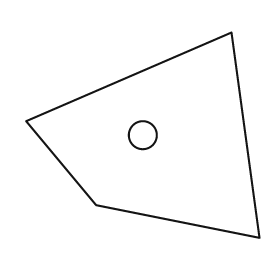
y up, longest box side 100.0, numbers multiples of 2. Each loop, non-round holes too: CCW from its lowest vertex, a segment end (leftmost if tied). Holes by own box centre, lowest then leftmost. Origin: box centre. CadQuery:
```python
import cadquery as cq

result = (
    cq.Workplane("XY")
    .moveTo(50.0, -44.0)
    .lineTo(38.0, 44.0)
    .lineTo(-50.0, 6.0)
    .lineTo(-20.0, -30.0)
    .close()
    .moveTo(0.0, 0.0)
    .circle(6.0)
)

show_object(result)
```